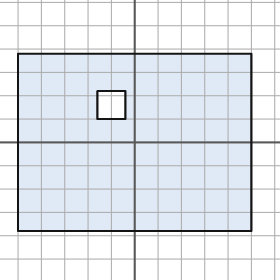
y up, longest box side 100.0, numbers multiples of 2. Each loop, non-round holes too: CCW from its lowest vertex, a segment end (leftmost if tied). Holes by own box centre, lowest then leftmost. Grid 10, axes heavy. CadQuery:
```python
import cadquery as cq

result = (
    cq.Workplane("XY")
    .moveTo(-50.0, -38.0)
    .lineTo(50.0, -38.0)
    .lineTo(50.0, 38.0)
    .lineTo(-50.0, 38.0)
    .close()
    .moveTo(-16.0, 10.0)
    .lineTo(-4.0, 10.0)
    .lineTo(-4.0, 22.0)
    .lineTo(-16.0, 22.0)
    .close()
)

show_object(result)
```